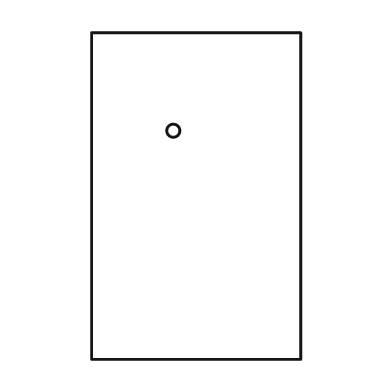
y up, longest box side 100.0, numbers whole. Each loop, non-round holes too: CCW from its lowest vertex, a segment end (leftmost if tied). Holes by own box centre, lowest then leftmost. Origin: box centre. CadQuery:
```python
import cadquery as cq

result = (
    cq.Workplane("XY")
    .moveTo(-32.0, -50.0)
    .lineTo(32.0, -50.0)
    .lineTo(32.0, 50.0)
    .lineTo(-32.0, 50.0)
    .close()
    .moveTo(-7.0, 20.0)
    .circle(2.0)
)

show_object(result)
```